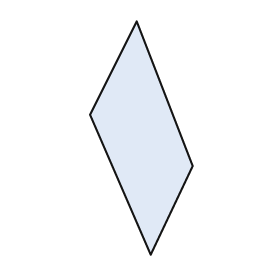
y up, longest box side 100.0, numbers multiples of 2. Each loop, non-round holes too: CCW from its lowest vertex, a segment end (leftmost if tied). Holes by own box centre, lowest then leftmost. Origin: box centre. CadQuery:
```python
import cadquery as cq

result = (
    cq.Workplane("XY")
    .moveTo(4.0, -50.0)
    .lineTo(22.0, -12.0)
    .lineTo(-2.0, 50.0)
    .lineTo(-22.0, 10.0)
    .close()
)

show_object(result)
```